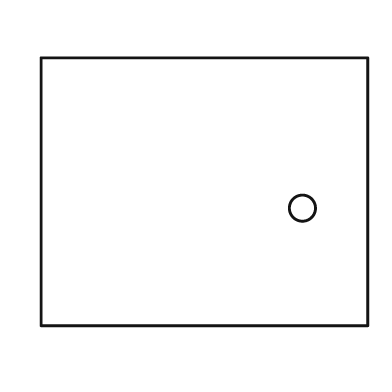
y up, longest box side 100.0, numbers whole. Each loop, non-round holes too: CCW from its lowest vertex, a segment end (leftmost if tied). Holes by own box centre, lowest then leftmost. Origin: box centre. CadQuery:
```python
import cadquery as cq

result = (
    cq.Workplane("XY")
    .moveTo(-50.0, -41.0)
    .lineTo(50.0, -41.0)
    .lineTo(50.0, 41.0)
    .lineTo(-50.0, 41.0)
    .close()
    .moveTo(30.0, -5.0)
    .circle(4.0)
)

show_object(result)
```